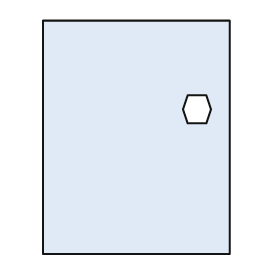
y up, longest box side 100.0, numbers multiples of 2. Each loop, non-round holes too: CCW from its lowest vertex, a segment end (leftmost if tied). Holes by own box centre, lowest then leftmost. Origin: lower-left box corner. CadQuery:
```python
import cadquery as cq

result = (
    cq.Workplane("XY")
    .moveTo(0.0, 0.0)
    .lineTo(80.0, 0.0)
    .lineTo(80.0, 100.0)
    .lineTo(0.0, 100.0)
    .close()
    .moveTo(62.0, 56.0)
    .lineTo(70.0, 56.0)
    .lineTo(72.0, 62.0)
    .lineTo(70.0, 68.0)
    .lineTo(62.0, 68.0)
    .lineTo(60.0, 62.0)
    .close()
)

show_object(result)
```